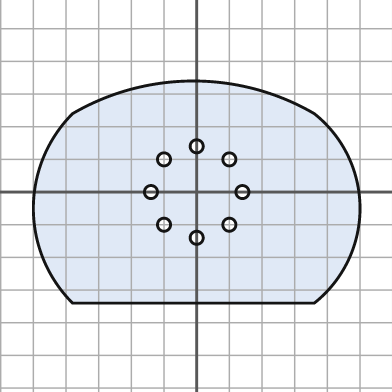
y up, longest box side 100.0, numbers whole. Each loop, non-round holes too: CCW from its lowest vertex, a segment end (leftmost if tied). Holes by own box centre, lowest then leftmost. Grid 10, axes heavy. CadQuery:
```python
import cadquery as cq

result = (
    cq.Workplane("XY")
    .moveTo(-38.0, -34.0)
    .lineTo(36.0, -34.0)
    .threePointArc((50.0, -5.0), (36.0, 24.0))
    .threePointArc((-1.0, 34.0), (-38.0, 24.0))
    .threePointArc((-50.0, -5.0), (-38.0, -34.0))
    .close()
    .moveTo(0.0, -14.0)
    .circle(2.0)
    .moveTo(-10.0, -10.0)
    .circle(2.0)
    .moveTo(10.0, -10.0)
    .circle(2.0)
    .moveTo(-14.0, 0.0)
    .circle(2.0)
    .moveTo(14.0, 0.0)
    .circle(2.0)
    .moveTo(-10.0, 10.0)
    .circle(2.0)
    .moveTo(10.0, 10.0)
    .circle(2.0)
    .moveTo(0.0, 14.0)
    .circle(2.0)
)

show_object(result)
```